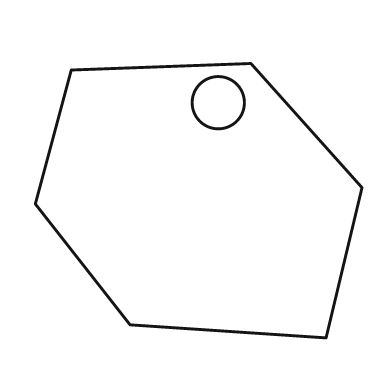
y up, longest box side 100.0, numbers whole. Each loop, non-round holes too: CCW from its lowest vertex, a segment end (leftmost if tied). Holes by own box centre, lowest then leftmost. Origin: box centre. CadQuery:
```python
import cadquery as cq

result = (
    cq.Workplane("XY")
    .moveTo(39.0, -42.0)
    .lineTo(50.0, 4.0)
    .lineTo(16.0, 42.0)
    .lineTo(-39.0, 40.0)
    .lineTo(-50.0, -1.0)
    .lineTo(-21.0, -38.0)
    .close()
    .moveTo(6.0, 30.0)
    .circle(8.0)
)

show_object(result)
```